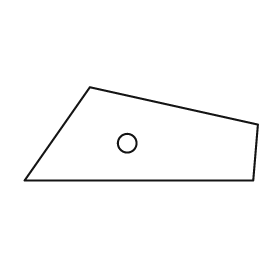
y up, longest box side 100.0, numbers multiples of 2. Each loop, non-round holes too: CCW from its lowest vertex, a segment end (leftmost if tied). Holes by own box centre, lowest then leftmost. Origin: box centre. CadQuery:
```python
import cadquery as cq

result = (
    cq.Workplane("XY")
    .moveTo(-50.0, -20.0)
    .lineTo(48.0, -20.0)
    .lineTo(50.0, 4.0)
    .lineTo(-22.0, 20.0)
    .close()
    .moveTo(-6.0, -4.0)
    .circle(4.0)
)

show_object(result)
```